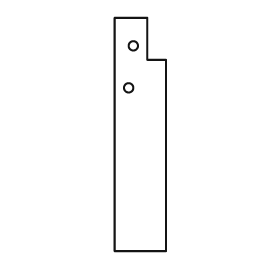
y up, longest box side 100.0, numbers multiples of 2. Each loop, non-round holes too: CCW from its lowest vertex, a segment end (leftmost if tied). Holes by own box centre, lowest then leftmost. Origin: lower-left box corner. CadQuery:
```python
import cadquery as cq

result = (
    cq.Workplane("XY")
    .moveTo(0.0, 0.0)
    .lineTo(22.0, 0.0)
    .lineTo(22.0, 82.0)
    .lineTo(14.0, 82.0)
    .lineTo(14.0, 100.0)
    .lineTo(0.0, 100.0)
    .close()
    .moveTo(6.0, 70.0)
    .circle(2.0)
    .moveTo(8.0, 88.0)
    .circle(2.0)
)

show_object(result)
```